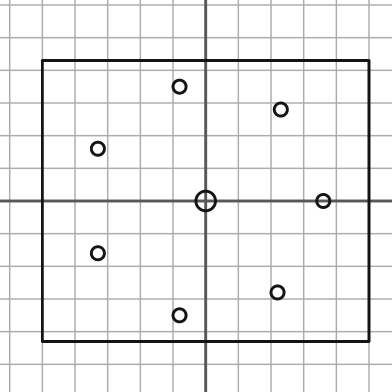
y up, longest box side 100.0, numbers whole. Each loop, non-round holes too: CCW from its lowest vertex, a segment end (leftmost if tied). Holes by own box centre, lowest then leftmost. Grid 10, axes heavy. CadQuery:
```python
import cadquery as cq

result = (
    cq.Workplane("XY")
    .moveTo(-50.0, -43.0)
    .lineTo(50.0, -43.0)
    .lineTo(50.0, 43.0)
    .lineTo(-50.0, 43.0)
    .close()
    .moveTo(-8.0, -35.0)
    .circle(2.0)
    .moveTo(22.0, -28.0)
    .circle(2.0)
    .moveTo(-33.0, -16.0)
    .circle(2.0)
    .moveTo(0.0, 0.0)
    .circle(3.0)
    .moveTo(36.0, 0.0)
    .circle(2.0)
    .moveTo(-33.0, 16.0)
    .circle(2.0)
    .moveTo(23.0, 28.0)
    .circle(2.0)
    .moveTo(-8.0, 35.0)
    .circle(2.0)
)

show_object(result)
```